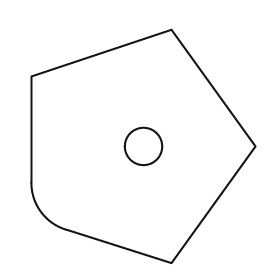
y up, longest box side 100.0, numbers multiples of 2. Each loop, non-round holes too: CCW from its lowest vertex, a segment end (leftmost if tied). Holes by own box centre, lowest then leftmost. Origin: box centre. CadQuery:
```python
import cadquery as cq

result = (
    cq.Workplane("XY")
    .moveTo(12.0, -50.0)
    .lineTo(48.0, 0.0)
    .lineTo(12.0, 50.0)
    .lineTo(-48.0, 30.0)
    .lineTo(-48.0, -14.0)
    .threePointArc((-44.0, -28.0), (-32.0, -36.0))
    .close()
    .moveTo(0.0, 0.0)
    .circle(8.0)
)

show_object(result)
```